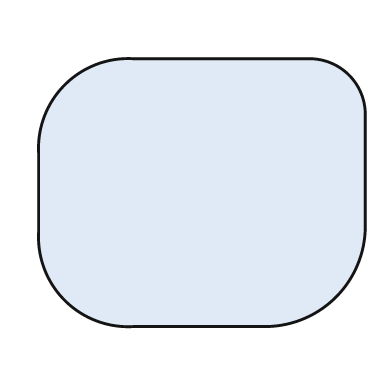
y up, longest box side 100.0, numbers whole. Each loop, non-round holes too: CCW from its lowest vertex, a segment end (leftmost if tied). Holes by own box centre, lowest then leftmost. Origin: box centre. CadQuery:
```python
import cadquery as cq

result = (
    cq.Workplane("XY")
    .moveTo(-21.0, -41.0)
    .lineTo(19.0, -41.0)
    .threePointArc((41.0, -32.0), (50.0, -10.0))
    .lineTo(50.0, 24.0)
    .threePointArc((45.0, 36.0), (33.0, 41.0))
    .lineTo(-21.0, 41.0)
    .threePointArc((-42.0, 33.0), (-50.0, 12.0))
    .lineTo(-50.0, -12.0)
    .threePointArc((-42.0, -33.0), (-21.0, -41.0))
    .close()
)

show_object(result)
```